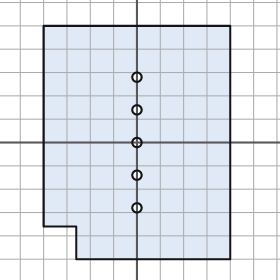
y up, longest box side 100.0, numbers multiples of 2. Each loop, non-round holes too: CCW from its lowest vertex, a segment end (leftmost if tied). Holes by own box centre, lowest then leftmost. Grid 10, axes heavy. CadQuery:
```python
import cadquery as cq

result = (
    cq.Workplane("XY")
    .moveTo(-26.0, -50.0)
    .lineTo(40.0, -50.0)
    .lineTo(40.0, 50.0)
    .lineTo(-40.0, 50.0)
    .lineTo(-40.0, -36.0)
    .lineTo(-26.0, -36.0)
    .close()
    .moveTo(0.0, -28.0)
    .circle(2.0)
    .moveTo(0.0, -14.0)
    .circle(2.0)
    .moveTo(0.0, 0.0)
    .circle(2.0)
    .moveTo(0.0, 14.0)
    .circle(2.0)
    .moveTo(0.0, 28.0)
    .circle(2.0)
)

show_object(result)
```